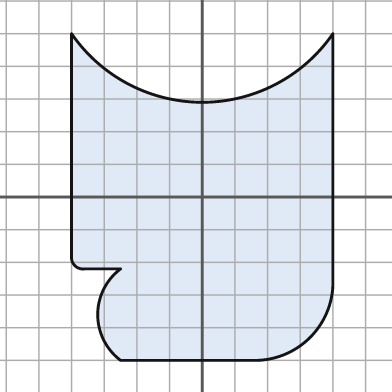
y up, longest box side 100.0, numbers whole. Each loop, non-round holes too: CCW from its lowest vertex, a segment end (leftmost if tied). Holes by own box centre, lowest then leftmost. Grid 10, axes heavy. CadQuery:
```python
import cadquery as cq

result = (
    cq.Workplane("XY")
    .moveTo(-25.0, -50.0)
    .lineTo(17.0, -50.0)
    .threePointArc((33.0, -43.0), (40.0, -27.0))
    .lineTo(40.0, 50.0)
    .threePointArc((0.0, 29.0), (-40.0, 50.0))
    .lineTo(-40.0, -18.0)
    .threePointArc((-39.0, -21.0), (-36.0, -22.0))
    .lineTo(-25.0, -22.0)
    .threePointArc((-32.0, -36.0), (-25.0, -50.0))
    .close()
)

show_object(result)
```